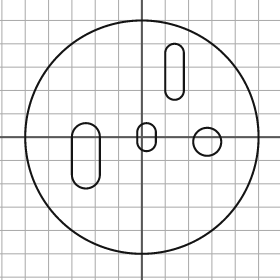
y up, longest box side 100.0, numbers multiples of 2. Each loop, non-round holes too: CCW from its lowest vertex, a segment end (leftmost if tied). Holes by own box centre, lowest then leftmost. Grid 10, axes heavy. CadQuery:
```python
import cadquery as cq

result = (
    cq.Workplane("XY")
    .moveTo(0.0, 0.0)
    .circle(50.0)
    .moveTo(-30.0, -16.0)
    .threePointArc((-24.0, -22.0), (-18.0, -16.0))
    .lineTo(-18.0, 0.0)
    .threePointArc((-24.0, 6.0), (-30.0, 0.0))
    .close()
    .moveTo(28.0, -2.0)
    .circle(6.0)
    .moveTo(-2.0, -2.0)
    .threePointArc((2.0, -6.0), (6.0, -2.0))
    .lineTo(6.0, 2.0)
    .threePointArc((2.0, 6.0), (-2.0, 2.0))
    .close()
    .moveTo(10.0, 20.0)
    .threePointArc((14.0, 16.0), (18.0, 20.0))
    .lineTo(18.0, 36.0)
    .threePointArc((14.0, 40.0), (10.0, 36.0))
    .close()
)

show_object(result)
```